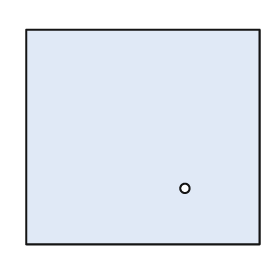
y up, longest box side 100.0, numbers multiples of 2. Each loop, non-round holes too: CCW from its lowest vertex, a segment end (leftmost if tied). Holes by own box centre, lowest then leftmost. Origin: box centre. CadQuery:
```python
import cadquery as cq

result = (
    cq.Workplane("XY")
    .moveTo(-50.0, -46.0)
    .lineTo(50.0, -46.0)
    .lineTo(50.0, 46.0)
    .lineTo(-50.0, 46.0)
    .close()
    .moveTo(18.0, -22.0)
    .circle(2.0)
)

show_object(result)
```